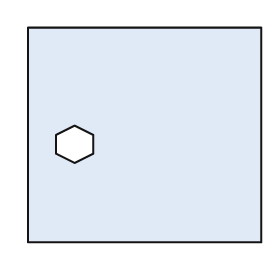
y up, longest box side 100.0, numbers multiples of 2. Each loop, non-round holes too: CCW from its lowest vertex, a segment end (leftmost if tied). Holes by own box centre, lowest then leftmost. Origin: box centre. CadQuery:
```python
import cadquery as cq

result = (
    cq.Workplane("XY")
    .moveTo(-50.0, -46.0)
    .lineTo(50.0, -46.0)
    .lineTo(50.0, 46.0)
    .lineTo(-50.0, 46.0)
    .close()
    .moveTo(-30.0, -12.0)
    .lineTo(-22.0, -8.0)
    .lineTo(-22.0, 0.0)
    .lineTo(-30.0, 4.0)
    .lineTo(-38.0, 0.0)
    .lineTo(-38.0, -8.0)
    .close()
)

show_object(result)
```